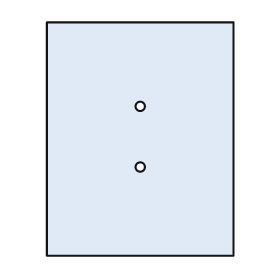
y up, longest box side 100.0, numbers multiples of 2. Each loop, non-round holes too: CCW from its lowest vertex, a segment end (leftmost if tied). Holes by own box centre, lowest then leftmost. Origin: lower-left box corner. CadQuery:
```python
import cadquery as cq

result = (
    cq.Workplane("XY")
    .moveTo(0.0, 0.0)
    .lineTo(80.0, 0.0)
    .lineTo(80.0, 100.0)
    .lineTo(0.0, 100.0)
    .close()
    .moveTo(40.0, 38.0)
    .circle(2.0)
    .moveTo(40.0, 64.0)
    .circle(2.0)
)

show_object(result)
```